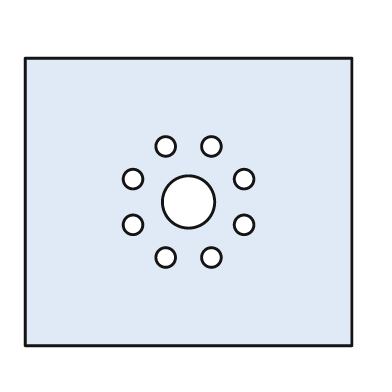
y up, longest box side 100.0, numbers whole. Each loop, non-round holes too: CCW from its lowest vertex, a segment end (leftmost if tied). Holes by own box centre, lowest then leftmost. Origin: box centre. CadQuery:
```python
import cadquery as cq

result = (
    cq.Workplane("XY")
    .moveTo(-50.0, -44.0)
    .lineTo(50.0, -44.0)
    .lineTo(50.0, 44.0)
    .lineTo(-50.0, 44.0)
    .close()
    .moveTo(-7.0, -17.0)
    .circle(3.0)
    .moveTo(7.0, -17.0)
    .circle(3.0)
    .moveTo(-17.0, -7.0)
    .circle(3.0)
    .moveTo(17.0, -7.0)
    .circle(3.0)
    .moveTo(0.0, 0.0)
    .circle(8.0)
    .moveTo(-17.0, 7.0)
    .circle(3.0)
    .moveTo(17.0, 7.0)
    .circle(3.0)
    .moveTo(-7.0, 17.0)
    .circle(3.0)
    .moveTo(7.0, 17.0)
    .circle(3.0)
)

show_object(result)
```